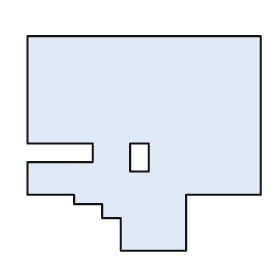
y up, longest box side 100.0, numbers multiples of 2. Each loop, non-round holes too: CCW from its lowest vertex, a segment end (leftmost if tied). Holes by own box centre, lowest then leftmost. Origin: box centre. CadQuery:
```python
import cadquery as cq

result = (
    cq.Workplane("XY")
    .moveTo(-10.0, -46.0)
    .lineTo(18.0, -46.0)
    .lineTo(18.0, -22.0)
    .lineTo(50.0, -22.0)
    .lineTo(50.0, 46.0)
    .lineTo(-50.0, 46.0)
    .lineTo(-50.0, 0.0)
    .lineTo(-22.0, 0.0)
    .lineTo(-22.0, -8.0)
    .lineTo(-50.0, -8.0)
    .lineTo(-50.0, -22.0)
    .lineTo(-30.0, -22.0)
    .lineTo(-30.0, -26.0)
    .lineTo(-18.0, -26.0)
    .lineTo(-18.0, -32.0)
    .lineTo(-10.0, -32.0)
    .close()
    .moveTo(-6.0, -12.0)
    .lineTo(2.0, -12.0)
    .lineTo(2.0, 0.0)
    .lineTo(-6.0, 0.0)
    .close()
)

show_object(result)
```